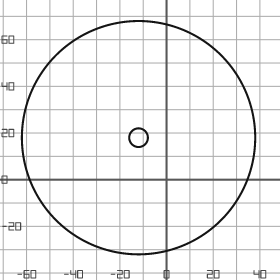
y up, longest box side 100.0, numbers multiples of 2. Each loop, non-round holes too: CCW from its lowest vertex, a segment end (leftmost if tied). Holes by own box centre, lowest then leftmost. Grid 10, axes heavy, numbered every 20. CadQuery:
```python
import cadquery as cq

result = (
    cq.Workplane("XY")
    .moveTo(-12.0, 18.0)
    .circle(50.0)
    .moveTo(-12.0, 18.0)
    .circle(4.0)
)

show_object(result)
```